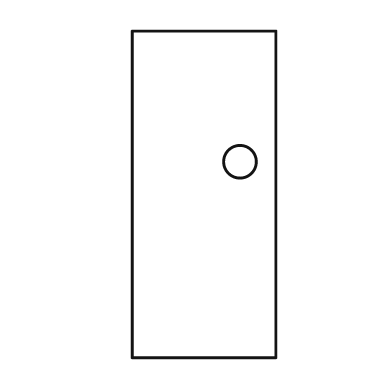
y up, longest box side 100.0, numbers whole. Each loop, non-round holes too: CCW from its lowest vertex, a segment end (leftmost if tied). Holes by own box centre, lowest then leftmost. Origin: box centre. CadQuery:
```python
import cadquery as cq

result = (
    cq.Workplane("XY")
    .moveTo(-22.0, -50.0)
    .lineTo(22.0, -50.0)
    .lineTo(22.0, 50.0)
    .lineTo(-22.0, 50.0)
    .close()
    .moveTo(11.0, 10.0)
    .circle(5.0)
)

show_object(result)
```